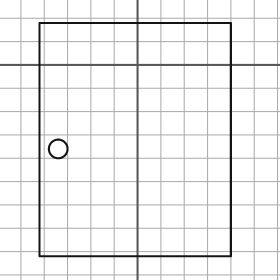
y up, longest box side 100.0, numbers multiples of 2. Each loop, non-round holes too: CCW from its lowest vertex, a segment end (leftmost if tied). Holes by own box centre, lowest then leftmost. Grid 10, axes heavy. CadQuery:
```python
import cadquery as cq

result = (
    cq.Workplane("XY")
    .moveTo(-42.0, -82.0)
    .lineTo(40.0, -82.0)
    .lineTo(40.0, 18.0)
    .lineTo(-42.0, 18.0)
    .close()
    .moveTo(-34.0, -36.0)
    .circle(4.0)
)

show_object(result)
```